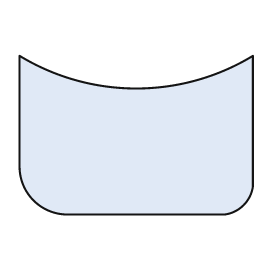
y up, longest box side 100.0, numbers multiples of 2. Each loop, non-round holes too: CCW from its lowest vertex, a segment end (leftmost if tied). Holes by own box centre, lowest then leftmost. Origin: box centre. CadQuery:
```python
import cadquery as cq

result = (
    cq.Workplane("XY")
    .moveTo(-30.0, -34.0)
    .lineTo(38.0, -34.0)
    .threePointArc((46.0, -30.0), (50.0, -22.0))
    .lineTo(50.0, 34.0)
    .threePointArc((0.0, 20.0), (-50.0, 34.0))
    .lineTo(-50.0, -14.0)
    .threePointArc((-44.0, -28.0), (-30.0, -34.0))
    .close()
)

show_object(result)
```